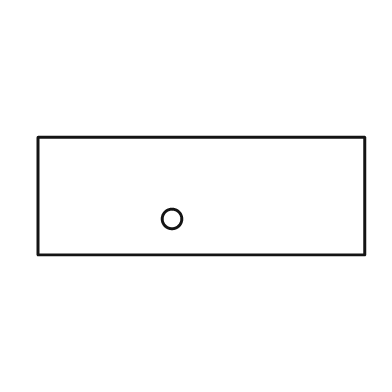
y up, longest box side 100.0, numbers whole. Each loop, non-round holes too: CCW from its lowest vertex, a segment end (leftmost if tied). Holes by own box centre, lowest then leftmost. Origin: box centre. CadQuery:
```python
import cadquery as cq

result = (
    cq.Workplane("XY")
    .moveTo(-50.0, -18.0)
    .lineTo(50.0, -18.0)
    .lineTo(50.0, 18.0)
    .lineTo(-50.0, 18.0)
    .close()
    .moveTo(-9.0, -7.0)
    .circle(3.0)
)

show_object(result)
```